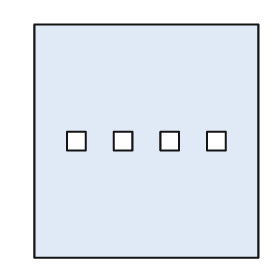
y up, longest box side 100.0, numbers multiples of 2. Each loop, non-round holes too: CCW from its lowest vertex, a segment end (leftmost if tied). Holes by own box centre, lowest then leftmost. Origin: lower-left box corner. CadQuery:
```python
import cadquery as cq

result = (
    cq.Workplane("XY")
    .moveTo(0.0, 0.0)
    .lineTo(96.0, 0.0)
    .lineTo(96.0, 100.0)
    .lineTo(0.0, 100.0)
    .close()
    .moveTo(14.0, 46.0)
    .lineTo(22.0, 46.0)
    .lineTo(22.0, 54.0)
    .lineTo(14.0, 54.0)
    .close()
    .moveTo(34.0, 46.0)
    .lineTo(42.0, 46.0)
    .lineTo(42.0, 54.0)
    .lineTo(34.0, 54.0)
    .close()
    .moveTo(54.0, 46.0)
    .lineTo(62.0, 46.0)
    .lineTo(62.0, 54.0)
    .lineTo(54.0, 54.0)
    .close()
    .moveTo(74.0, 46.0)
    .lineTo(82.0, 46.0)
    .lineTo(82.0, 54.0)
    .lineTo(74.0, 54.0)
    .close()
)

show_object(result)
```